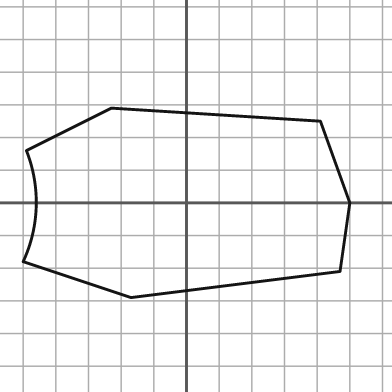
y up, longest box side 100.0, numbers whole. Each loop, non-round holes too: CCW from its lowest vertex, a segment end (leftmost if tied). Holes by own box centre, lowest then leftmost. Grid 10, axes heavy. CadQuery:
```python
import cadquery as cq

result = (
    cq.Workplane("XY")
    .moveTo(-17.0, -29.0)
    .lineTo(47.0, -21.0)
    .lineTo(50.0, 0.0)
    .lineTo(41.0, 25.0)
    .lineTo(-23.0, 29.0)
    .lineTo(-49.0, 16.0)
    .threePointArc((-46.0, -1.0), (-50.0, -18.0))
    .close()
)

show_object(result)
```